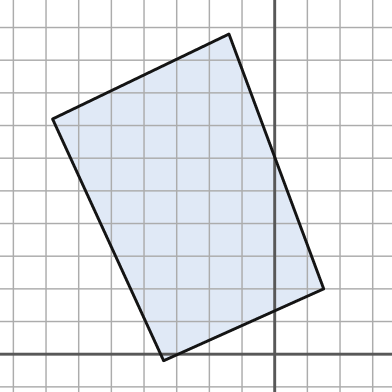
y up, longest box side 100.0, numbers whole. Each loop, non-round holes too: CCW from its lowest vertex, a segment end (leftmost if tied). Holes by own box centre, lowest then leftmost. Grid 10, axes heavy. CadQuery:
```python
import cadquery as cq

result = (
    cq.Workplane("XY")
    .moveTo(-34.0, -2.0)
    .lineTo(15.0, 20.0)
    .lineTo(-14.0, 98.0)
    .lineTo(-68.0, 72.0)
    .close()
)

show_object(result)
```